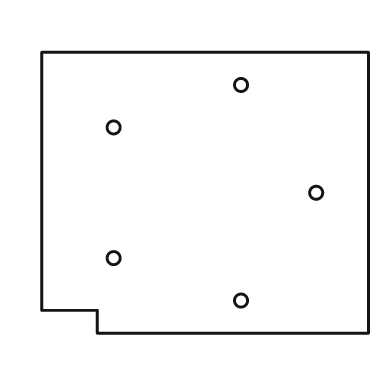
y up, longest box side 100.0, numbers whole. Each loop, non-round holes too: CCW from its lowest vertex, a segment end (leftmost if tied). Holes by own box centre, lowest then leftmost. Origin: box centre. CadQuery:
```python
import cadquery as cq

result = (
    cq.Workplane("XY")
    .moveTo(-33.0, -43.0)
    .lineTo(50.0, -43.0)
    .lineTo(50.0, 43.0)
    .lineTo(-50.0, 43.0)
    .lineTo(-50.0, -36.0)
    .lineTo(-33.0, -36.0)
    .close()
    .moveTo(11.0, -33.0)
    .circle(2.0)
    .moveTo(-28.0, -20.0)
    .circle(2.0)
    .moveTo(34.0, 0.0)
    .circle(2.0)
    .moveTo(-28.0, 20.0)
    .circle(2.0)
    .moveTo(11.0, 33.0)
    .circle(2.0)
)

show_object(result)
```